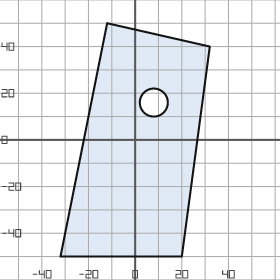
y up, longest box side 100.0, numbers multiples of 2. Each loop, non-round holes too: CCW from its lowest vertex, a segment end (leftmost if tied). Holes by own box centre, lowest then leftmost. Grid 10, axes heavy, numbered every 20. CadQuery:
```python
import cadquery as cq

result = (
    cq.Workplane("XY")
    .moveTo(-32.0, -50.0)
    .lineTo(20.0, -50.0)
    .lineTo(32.0, 40.0)
    .lineTo(-12.0, 50.0)
    .close()
    .moveTo(8.0, 16.0)
    .circle(6.0)
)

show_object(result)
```